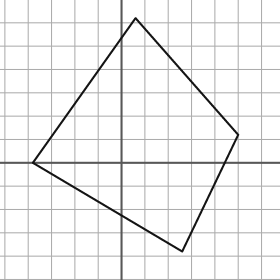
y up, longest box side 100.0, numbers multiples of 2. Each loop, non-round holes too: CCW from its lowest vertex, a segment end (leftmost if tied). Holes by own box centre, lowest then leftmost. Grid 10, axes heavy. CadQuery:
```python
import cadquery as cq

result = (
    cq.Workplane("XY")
    .moveTo(26.0, -38.0)
    .lineTo(50.0, 12.0)
    .lineTo(6.0, 62.0)
    .lineTo(-38.0, 0.0)
    .close()
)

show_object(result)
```